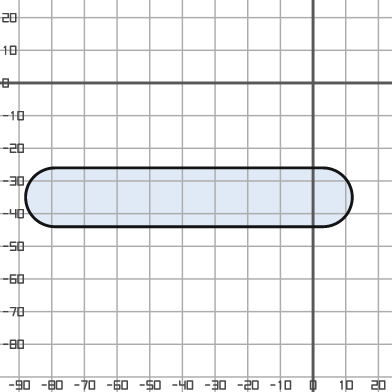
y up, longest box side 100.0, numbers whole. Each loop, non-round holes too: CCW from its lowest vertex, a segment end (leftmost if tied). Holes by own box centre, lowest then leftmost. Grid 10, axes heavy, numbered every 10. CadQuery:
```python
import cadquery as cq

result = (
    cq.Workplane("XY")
    .moveTo(-79.0, -44.0)
    .lineTo(3.0, -44.0)
    .threePointArc((12.0, -35.0), (3.0, -26.0))
    .lineTo(-79.0, -26.0)
    .threePointArc((-88.0, -35.0), (-79.0, -44.0))
    .close()
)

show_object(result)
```